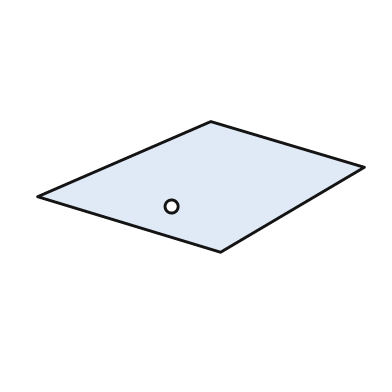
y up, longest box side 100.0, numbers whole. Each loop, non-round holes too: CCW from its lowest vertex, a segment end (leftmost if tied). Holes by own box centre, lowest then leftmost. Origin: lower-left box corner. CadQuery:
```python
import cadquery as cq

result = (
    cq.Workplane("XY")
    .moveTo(56.0, 0.0)
    .lineTo(100.0, 26.0)
    .lineTo(53.0, 40.0)
    .lineTo(0.0, 17.0)
    .close()
    .moveTo(41.0, 14.0)
    .circle(2.0)
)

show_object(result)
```